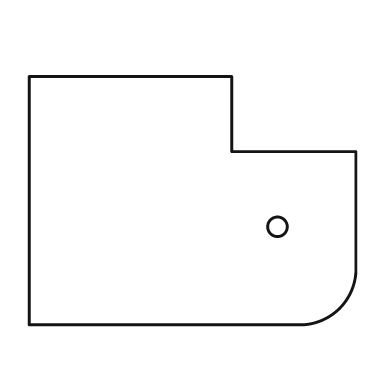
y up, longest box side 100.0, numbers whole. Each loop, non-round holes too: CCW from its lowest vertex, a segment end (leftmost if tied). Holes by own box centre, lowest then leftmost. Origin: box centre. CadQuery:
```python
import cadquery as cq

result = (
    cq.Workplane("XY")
    .moveTo(-50.0, -38.0)
    .lineTo(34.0, -38.0)
    .threePointArc((45.0, -33.0), (50.0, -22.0))
    .lineTo(50.0, 15.0)
    .lineTo(12.0, 15.0)
    .lineTo(12.0, 38.0)
    .lineTo(-50.0, 38.0)
    .close()
    .moveTo(26.0, -8.0)
    .circle(3.0)
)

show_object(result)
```